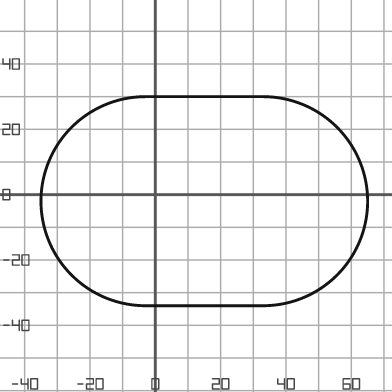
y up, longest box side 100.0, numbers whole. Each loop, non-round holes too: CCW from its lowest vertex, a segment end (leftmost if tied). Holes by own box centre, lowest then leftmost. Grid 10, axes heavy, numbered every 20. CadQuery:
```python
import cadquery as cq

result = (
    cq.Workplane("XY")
    .moveTo(-3.0, -34.0)
    .lineTo(33.0, -34.0)
    .threePointArc((65.0, -2.0), (33.0, 30.0))
    .lineTo(-3.0, 30.0)
    .threePointArc((-35.0, -2.0), (-3.0, -34.0))
    .close()
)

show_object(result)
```